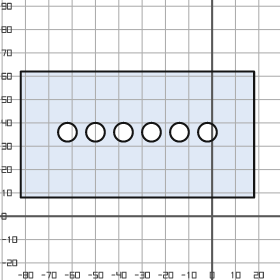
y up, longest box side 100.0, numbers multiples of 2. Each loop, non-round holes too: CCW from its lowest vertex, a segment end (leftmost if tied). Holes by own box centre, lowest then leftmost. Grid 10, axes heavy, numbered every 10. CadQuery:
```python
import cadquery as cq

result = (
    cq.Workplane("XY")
    .moveTo(-82.0, 8.0)
    .lineTo(18.0, 8.0)
    .lineTo(18.0, 62.0)
    .lineTo(-82.0, 62.0)
    .close()
    .moveTo(-62.0, 36.0)
    .circle(4.0)
    .moveTo(-50.0, 36.0)
    .circle(4.0)
    .moveTo(-38.0, 36.0)
    .circle(4.0)
    .moveTo(-26.0, 36.0)
    .circle(4.0)
    .moveTo(-14.0, 36.0)
    .circle(4.0)
    .moveTo(-2.0, 36.0)
    .circle(4.0)
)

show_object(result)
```